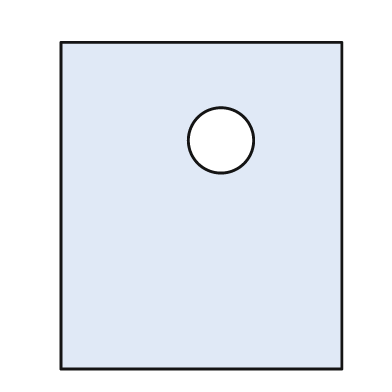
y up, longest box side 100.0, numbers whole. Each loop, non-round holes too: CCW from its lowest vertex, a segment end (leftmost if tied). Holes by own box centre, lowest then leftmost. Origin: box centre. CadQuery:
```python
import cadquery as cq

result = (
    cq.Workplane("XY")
    .moveTo(-43.0, -50.0)
    .lineTo(43.0, -50.0)
    .lineTo(43.0, 50.0)
    .lineTo(-43.0, 50.0)
    .close()
    .moveTo(6.0, 20.0)
    .circle(10.0)
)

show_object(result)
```